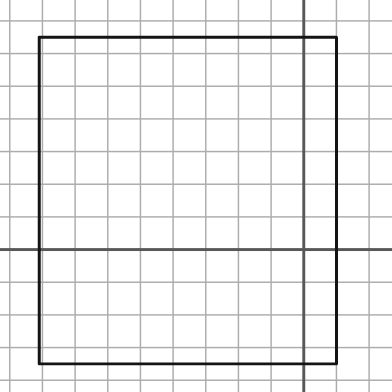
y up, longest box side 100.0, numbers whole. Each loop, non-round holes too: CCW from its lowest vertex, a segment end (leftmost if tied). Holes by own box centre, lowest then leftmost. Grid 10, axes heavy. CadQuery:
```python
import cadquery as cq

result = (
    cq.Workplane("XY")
    .moveTo(-81.0, -35.0)
    .lineTo(10.0, -35.0)
    .lineTo(10.0, 65.0)
    .lineTo(-81.0, 65.0)
    .close()
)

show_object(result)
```